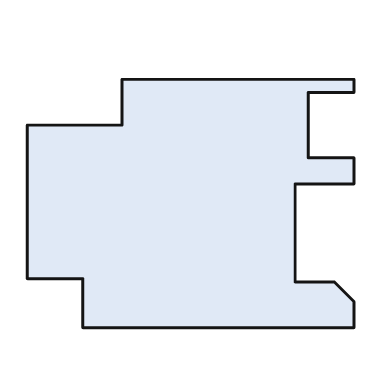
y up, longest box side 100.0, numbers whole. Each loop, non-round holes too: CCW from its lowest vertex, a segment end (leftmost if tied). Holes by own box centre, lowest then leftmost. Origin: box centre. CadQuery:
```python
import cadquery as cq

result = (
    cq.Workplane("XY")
    .moveTo(-33.0, -38.0)
    .lineTo(50.0, -38.0)
    .lineTo(50.0, -30.0)
    .lineTo(44.0, -24.0)
    .lineTo(32.0, -24.0)
    .lineTo(32.0, 6.0)
    .lineTo(50.0, 6.0)
    .lineTo(50.0, 14.0)
    .lineTo(36.0, 14.0)
    .lineTo(36.0, 34.0)
    .lineTo(50.0, 34.0)
    .lineTo(50.0, 38.0)
    .lineTo(-21.0, 38.0)
    .lineTo(-21.0, 24.0)
    .lineTo(-50.0, 24.0)
    .lineTo(-50.0, -23.0)
    .lineTo(-33.0, -23.0)
    .close()
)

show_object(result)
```